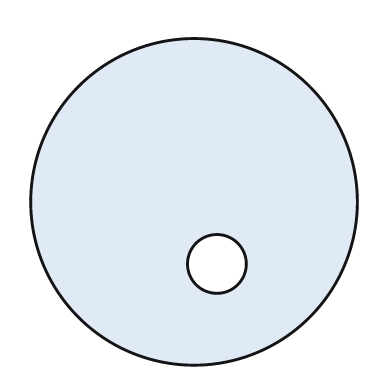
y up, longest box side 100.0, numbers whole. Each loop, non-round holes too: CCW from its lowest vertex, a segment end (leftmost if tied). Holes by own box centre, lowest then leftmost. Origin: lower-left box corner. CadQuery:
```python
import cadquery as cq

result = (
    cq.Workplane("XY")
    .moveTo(50.0, 50.0)
    .circle(50.0)
    .moveTo(57.0, 31.0)
    .circle(9.0)
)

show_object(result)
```